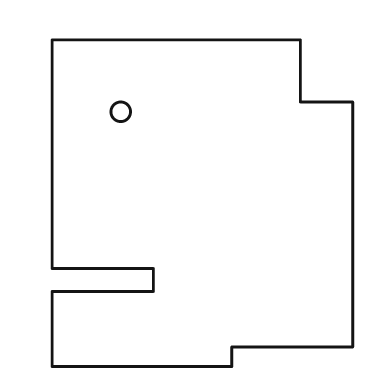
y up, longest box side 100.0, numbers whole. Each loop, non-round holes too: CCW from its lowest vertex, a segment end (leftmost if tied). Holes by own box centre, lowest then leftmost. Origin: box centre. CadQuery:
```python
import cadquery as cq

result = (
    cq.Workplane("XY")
    .moveTo(-46.0, -50.0)
    .lineTo(9.0, -50.0)
    .lineTo(9.0, -44.0)
    .lineTo(46.0, -44.0)
    .lineTo(46.0, 31.0)
    .lineTo(30.0, 31.0)
    .lineTo(30.0, 50.0)
    .lineTo(-46.0, 50.0)
    .lineTo(-46.0, -20.0)
    .lineTo(-15.0, -20.0)
    .lineTo(-15.0, -27.0)
    .lineTo(-46.0, -27.0)
    .close()
    .moveTo(-25.0, 28.0)
    .circle(3.0)
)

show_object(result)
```